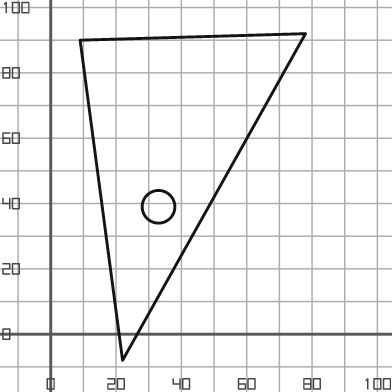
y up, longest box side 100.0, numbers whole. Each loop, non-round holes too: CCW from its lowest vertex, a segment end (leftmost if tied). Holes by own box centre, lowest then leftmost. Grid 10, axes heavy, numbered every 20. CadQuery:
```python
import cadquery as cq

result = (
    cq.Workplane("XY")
    .moveTo(22.0, -8.0)
    .lineTo(78.0, 92.0)
    .lineTo(9.0, 90.0)
    .close()
    .moveTo(33.0, 39.0)
    .circle(5.0)
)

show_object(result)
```